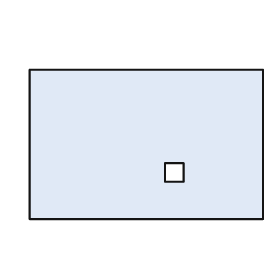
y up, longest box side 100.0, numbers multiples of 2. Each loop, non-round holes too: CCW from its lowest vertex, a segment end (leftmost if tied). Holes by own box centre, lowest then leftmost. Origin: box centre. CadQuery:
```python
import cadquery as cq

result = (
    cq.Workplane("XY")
    .moveTo(-50.0, -32.0)
    .lineTo(50.0, -32.0)
    .lineTo(50.0, 32.0)
    .lineTo(-50.0, 32.0)
    .close()
    .moveTo(8.0, -16.0)
    .lineTo(16.0, -16.0)
    .lineTo(16.0, -8.0)
    .lineTo(8.0, -8.0)
    .close()
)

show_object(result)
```